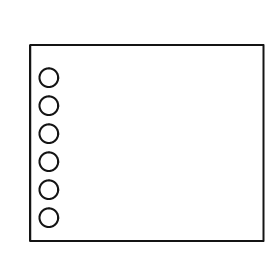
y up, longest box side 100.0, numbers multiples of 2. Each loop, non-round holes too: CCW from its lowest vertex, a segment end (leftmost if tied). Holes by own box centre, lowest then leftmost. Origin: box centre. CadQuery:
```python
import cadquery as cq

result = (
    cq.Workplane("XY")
    .moveTo(-50.0, -42.0)
    .lineTo(50.0, -42.0)
    .lineTo(50.0, 42.0)
    .lineTo(-50.0, 42.0)
    .close()
    .moveTo(-42.0, -32.0)
    .circle(4.0)
    .moveTo(-42.0, -20.0)
    .circle(4.0)
    .moveTo(-42.0, -8.0)
    .circle(4.0)
    .moveTo(-42.0, 4.0)
    .circle(4.0)
    .moveTo(-42.0, 16.0)
    .circle(4.0)
    .moveTo(-42.0, 28.0)
    .circle(4.0)
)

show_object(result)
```